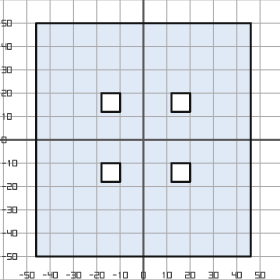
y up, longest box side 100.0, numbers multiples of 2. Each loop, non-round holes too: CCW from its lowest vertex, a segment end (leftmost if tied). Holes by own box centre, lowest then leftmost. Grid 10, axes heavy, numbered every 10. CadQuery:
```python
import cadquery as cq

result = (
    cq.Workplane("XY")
    .moveTo(-46.0, -50.0)
    .lineTo(46.0, -50.0)
    .lineTo(46.0, 50.0)
    .lineTo(-46.0, 50.0)
    .close()
    .moveTo(-18.0, -18.0)
    .lineTo(-10.0, -18.0)
    .lineTo(-10.0, -10.0)
    .lineTo(-18.0, -10.0)
    .close()
    .moveTo(12.0, -18.0)
    .lineTo(20.0, -18.0)
    .lineTo(20.0, -10.0)
    .lineTo(12.0, -10.0)
    .close()
    .moveTo(-18.0, 12.0)
    .lineTo(-10.0, 12.0)
    .lineTo(-10.0, 20.0)
    .lineTo(-18.0, 20.0)
    .close()
    .moveTo(12.0, 12.0)
    .lineTo(20.0, 12.0)
    .lineTo(20.0, 20.0)
    .lineTo(12.0, 20.0)
    .close()
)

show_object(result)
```